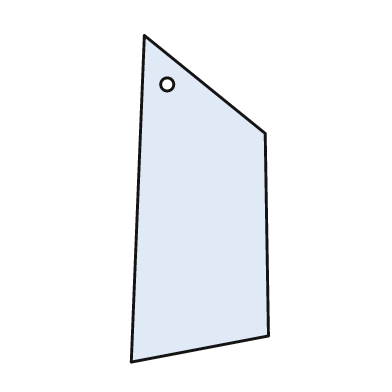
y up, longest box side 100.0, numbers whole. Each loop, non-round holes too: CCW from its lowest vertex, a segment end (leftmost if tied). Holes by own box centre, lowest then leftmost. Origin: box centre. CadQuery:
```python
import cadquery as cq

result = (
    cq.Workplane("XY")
    .moveTo(-21.0, -50.0)
    .lineTo(21.0, -42.0)
    .lineTo(20.0, 20.0)
    .lineTo(-17.0, 50.0)
    .close()
    .moveTo(-10.0, 35.0)
    .circle(2.0)
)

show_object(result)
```